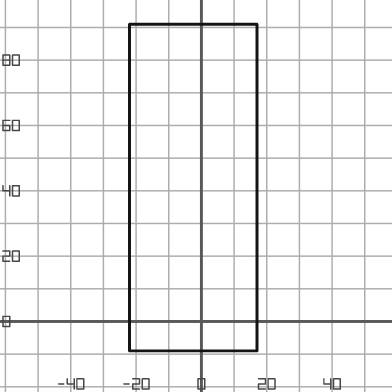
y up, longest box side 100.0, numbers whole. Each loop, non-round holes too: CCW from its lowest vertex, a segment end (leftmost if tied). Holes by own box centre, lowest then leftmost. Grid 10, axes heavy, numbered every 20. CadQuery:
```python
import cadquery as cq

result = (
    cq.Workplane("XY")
    .moveTo(-22.0, -9.0)
    .lineTo(17.0, -9.0)
    .lineTo(17.0, 91.0)
    .lineTo(-22.0, 91.0)
    .close()
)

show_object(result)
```